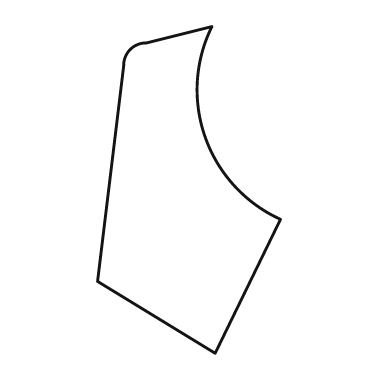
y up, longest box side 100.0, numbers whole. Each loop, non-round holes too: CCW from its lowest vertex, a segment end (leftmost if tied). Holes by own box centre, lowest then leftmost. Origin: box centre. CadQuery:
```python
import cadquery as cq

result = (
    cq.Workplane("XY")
    .moveTo(8.0, -50.0)
    .lineTo(28.0, -9.0)
    .threePointArc((5.0, 16.0), (7.0, 50.0))
    .lineTo(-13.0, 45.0)
    .threePointArc((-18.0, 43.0), (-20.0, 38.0))
    .lineTo(-28.0, -28.0)
    .close()
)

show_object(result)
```